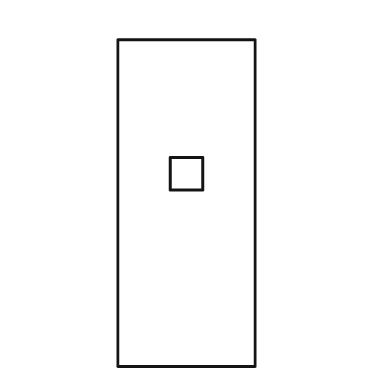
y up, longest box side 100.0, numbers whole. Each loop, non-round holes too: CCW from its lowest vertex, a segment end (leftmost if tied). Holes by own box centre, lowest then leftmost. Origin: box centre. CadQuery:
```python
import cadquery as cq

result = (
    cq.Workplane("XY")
    .moveTo(-21.0, -50.0)
    .lineTo(21.0, -50.0)
    .lineTo(21.0, 50.0)
    .lineTo(-21.0, 50.0)
    .close()
    .moveTo(-5.0, 4.0)
    .lineTo(5.0, 4.0)
    .lineTo(5.0, 14.0)
    .lineTo(-5.0, 14.0)
    .close()
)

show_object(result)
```